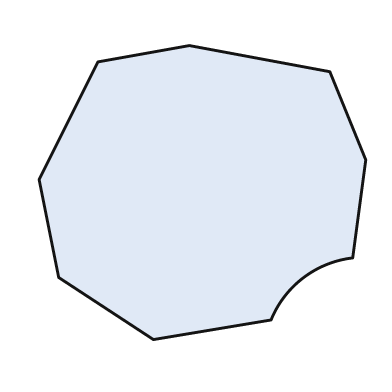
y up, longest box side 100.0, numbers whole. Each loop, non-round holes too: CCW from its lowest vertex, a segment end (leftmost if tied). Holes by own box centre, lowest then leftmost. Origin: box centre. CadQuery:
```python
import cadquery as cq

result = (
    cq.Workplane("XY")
    .moveTo(-15.0, -45.0)
    .lineTo(21.0, -39.0)
    .threePointArc((31.0, -26.0), (46.0, -20.0))
    .lineTo(50.0, 10.0)
    .lineTo(39.0, 37.0)
    .lineTo(-4.0, 45.0)
    .lineTo(-32.0, 40.0)
    .lineTo(-50.0, 4.0)
    .lineTo(-44.0, -26.0)
    .close()
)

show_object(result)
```